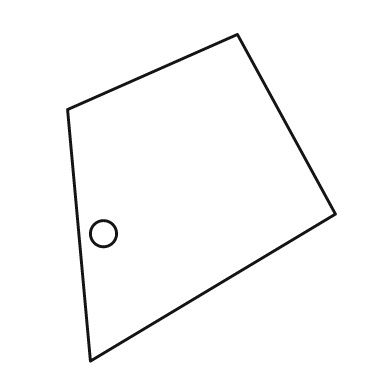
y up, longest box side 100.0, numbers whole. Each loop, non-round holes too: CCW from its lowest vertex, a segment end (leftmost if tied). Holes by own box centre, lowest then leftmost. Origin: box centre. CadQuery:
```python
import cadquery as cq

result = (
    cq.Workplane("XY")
    .moveTo(-34.0, -50.0)
    .lineTo(41.0, -5.0)
    .lineTo(11.0, 50.0)
    .lineTo(-41.0, 27.0)
    .close()
    .moveTo(-30.0, -11.0)
    .circle(4.0)
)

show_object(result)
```